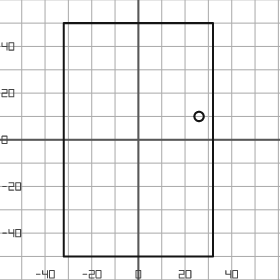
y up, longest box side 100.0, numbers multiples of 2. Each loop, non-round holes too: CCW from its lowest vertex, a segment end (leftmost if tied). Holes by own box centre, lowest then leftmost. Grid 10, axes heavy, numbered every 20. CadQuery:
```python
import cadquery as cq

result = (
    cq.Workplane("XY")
    .moveTo(-32.0, -50.0)
    .lineTo(32.0, -50.0)
    .lineTo(32.0, 50.0)
    .lineTo(-32.0, 50.0)
    .close()
    .moveTo(26.0, 10.0)
    .circle(2.0)
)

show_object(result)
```